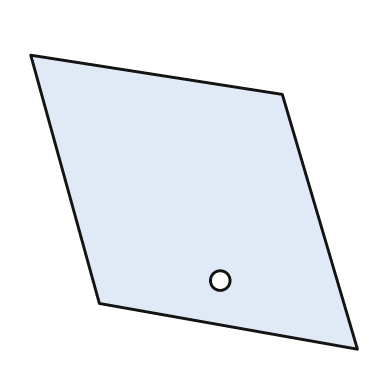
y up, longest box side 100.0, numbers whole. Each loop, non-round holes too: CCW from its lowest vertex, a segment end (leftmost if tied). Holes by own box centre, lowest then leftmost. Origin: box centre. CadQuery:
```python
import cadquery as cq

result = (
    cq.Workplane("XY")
    .moveTo(50.0, -45.0)
    .lineTo(27.0, 33.0)
    .lineTo(-50.0, 45.0)
    .lineTo(-29.0, -31.0)
    .close()
    .moveTo(8.0, -24.0)
    .circle(3.0)
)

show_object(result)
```